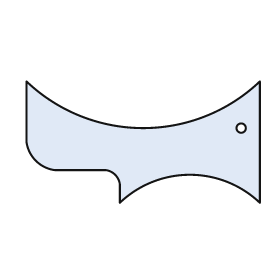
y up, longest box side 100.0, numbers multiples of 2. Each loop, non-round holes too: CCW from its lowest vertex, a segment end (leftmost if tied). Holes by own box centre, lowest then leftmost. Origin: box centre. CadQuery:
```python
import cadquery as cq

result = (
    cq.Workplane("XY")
    .moveTo(-10.0, -26.0)
    .threePointArc((20.0, -14.0), (50.0, -26.0))
    .lineTo(50.0, 26.0)
    .threePointArc((0.0, 6.0), (-50.0, 26.0))
    .lineTo(-50.0, 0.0)
    .threePointArc((-46.0, -8.0), (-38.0, -12.0))
    .lineTo(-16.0, -12.0)
    .threePointArc((-12.0, -14.0), (-10.0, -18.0))
    .close()
    .moveTo(42.0, 6.0)
    .circle(2.0)
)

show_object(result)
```